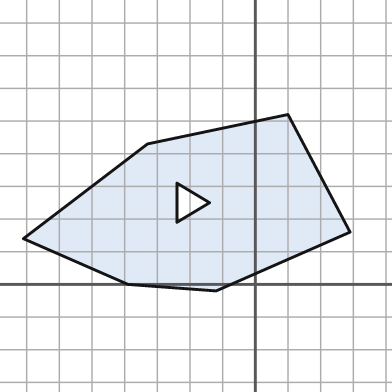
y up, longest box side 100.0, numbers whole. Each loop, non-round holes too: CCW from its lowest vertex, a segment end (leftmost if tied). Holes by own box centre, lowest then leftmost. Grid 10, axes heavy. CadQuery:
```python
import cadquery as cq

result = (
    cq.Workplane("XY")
    .moveTo(-12.0, -2.0)
    .lineTo(29.0, 16.0)
    .lineTo(10.0, 52.0)
    .lineTo(-33.0, 43.0)
    .lineTo(-71.0, 14.0)
    .lineTo(-39.0, 0.0)
    .close()
    .moveTo(-24.0, 19.0)
    .lineTo(-14.0, 25.0)
    .lineTo(-24.0, 31.0)
    .close()
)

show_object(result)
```